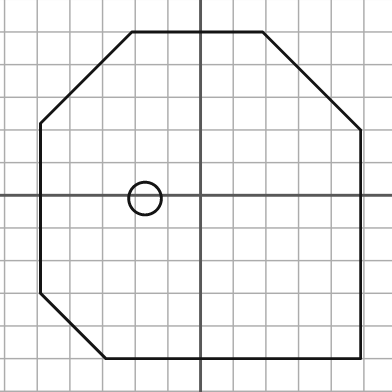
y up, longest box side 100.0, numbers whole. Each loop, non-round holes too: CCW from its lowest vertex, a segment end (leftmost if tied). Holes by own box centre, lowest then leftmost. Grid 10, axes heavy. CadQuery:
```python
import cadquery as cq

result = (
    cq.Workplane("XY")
    .moveTo(-29.0, -50.0)
    .lineTo(49.0, -50.0)
    .lineTo(49.0, 20.0)
    .lineTo(19.0, 50.0)
    .lineTo(-21.0, 50.0)
    .lineTo(-49.0, 22.0)
    .lineTo(-49.0, -30.0)
    .close()
    .moveTo(-17.0, -1.0)
    .circle(5.0)
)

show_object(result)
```